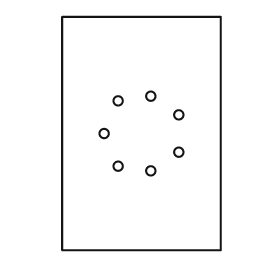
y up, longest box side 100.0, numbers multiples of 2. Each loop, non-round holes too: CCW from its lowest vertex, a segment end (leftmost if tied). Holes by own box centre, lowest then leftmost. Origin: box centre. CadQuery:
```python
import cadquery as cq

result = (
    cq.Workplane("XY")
    .moveTo(-34.0, -50.0)
    .lineTo(34.0, -50.0)
    .lineTo(34.0, 50.0)
    .lineTo(-34.0, 50.0)
    .close()
    .moveTo(4.0, -16.0)
    .circle(2.0)
    .moveTo(-10.0, -14.0)
    .circle(2.0)
    .moveTo(16.0, -8.0)
    .circle(2.0)
    .moveTo(-16.0, 0.0)
    .circle(2.0)
    .moveTo(16.0, 8.0)
    .circle(2.0)
    .moveTo(-10.0, 14.0)
    .circle(2.0)
    .moveTo(4.0, 16.0)
    .circle(2.0)
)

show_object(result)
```